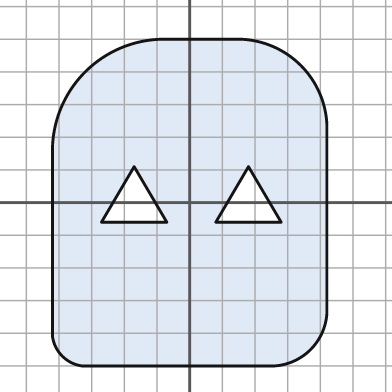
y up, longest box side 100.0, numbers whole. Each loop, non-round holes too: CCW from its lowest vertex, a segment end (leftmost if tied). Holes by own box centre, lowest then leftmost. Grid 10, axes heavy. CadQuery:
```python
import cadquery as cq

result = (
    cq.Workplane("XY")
    .moveTo(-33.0, -50.0)
    .lineTo(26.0, -50.0)
    .threePointArc((37.0, -45.0), (42.0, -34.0))
    .lineTo(42.0, 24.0)
    .threePointArc((34.0, 42.0), (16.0, 50.0))
    .lineTo(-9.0, 50.0)
    .threePointArc((-32.0, 40.0), (-42.0, 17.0))
    .lineTo(-42.0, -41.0)
    .threePointArc((-39.0, -47.0), (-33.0, -50.0))
    .close()
    .moveTo(-27.0, -6.0)
    .lineTo(-7.0, -6.0)
    .lineTo(-17.0, 11.0)
    .close()
    .moveTo(8.0, -6.0)
    .lineTo(28.0, -6.0)
    .lineTo(18.0, 11.0)
    .close()
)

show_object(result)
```